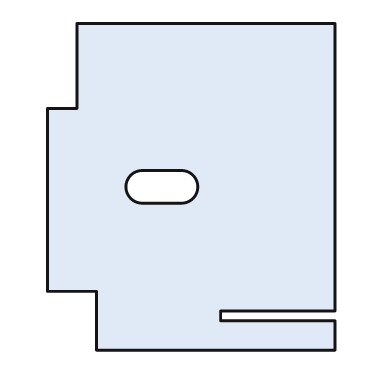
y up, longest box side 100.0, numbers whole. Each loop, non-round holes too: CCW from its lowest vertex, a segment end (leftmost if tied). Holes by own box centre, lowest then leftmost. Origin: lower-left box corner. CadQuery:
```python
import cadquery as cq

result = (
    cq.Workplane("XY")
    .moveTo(15.0, 0.0)
    .lineTo(88.0, 0.0)
    .lineTo(88.0, 9.0)
    .lineTo(53.0, 9.0)
    .lineTo(53.0, 12.0)
    .lineTo(88.0, 12.0)
    .lineTo(88.0, 100.0)
    .lineTo(9.0, 100.0)
    .lineTo(9.0, 74.0)
    .lineTo(0.0, 74.0)
    .lineTo(0.0, 18.0)
    .lineTo(15.0, 18.0)
    .close()
    .moveTo(29.0, 45.0)
    .lineTo(41.0, 45.0)
    .threePointArc((46.0, 50.0), (41.0, 55.0))
    .lineTo(29.0, 55.0)
    .threePointArc((24.0, 50.0), (29.0, 45.0))
    .close()
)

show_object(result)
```